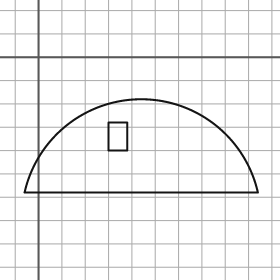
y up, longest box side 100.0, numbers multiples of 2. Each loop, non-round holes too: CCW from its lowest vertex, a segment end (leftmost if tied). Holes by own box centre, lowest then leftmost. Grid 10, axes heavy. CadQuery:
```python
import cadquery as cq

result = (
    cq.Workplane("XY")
    .moveTo(-6.0, -58.0)
    .lineTo(94.0, -58.0)
    .threePointArc((44.0, -18.0), (-6.0, -58.0))
    .close()
    .moveTo(30.0, -40.0)
    .lineTo(38.0, -40.0)
    .lineTo(38.0, -28.0)
    .lineTo(30.0, -28.0)
    .close()
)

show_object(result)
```